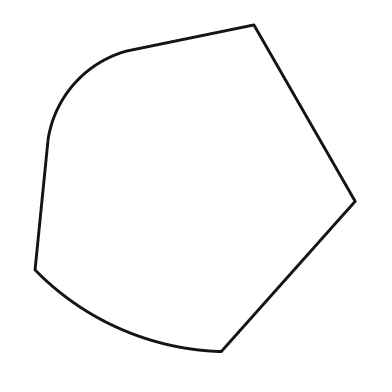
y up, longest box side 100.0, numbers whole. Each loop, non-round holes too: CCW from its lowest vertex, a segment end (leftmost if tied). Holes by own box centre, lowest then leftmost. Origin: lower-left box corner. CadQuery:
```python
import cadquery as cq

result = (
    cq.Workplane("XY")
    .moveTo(57.0, 0.0)
    .lineTo(98.0, 46.0)
    .lineTo(67.0, 100.0)
    .lineTo(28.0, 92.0)
    .threePointArc((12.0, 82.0), (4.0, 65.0))
    .lineTo(0.0, 25.0)
    .threePointArc((26.0, 7.0), (57.0, 0.0))
    .close()
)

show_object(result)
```